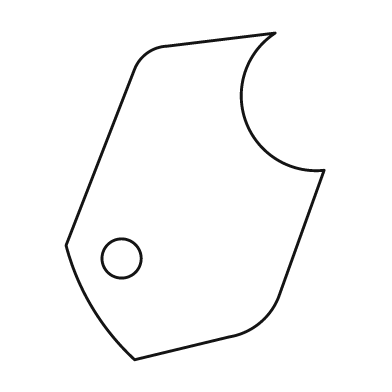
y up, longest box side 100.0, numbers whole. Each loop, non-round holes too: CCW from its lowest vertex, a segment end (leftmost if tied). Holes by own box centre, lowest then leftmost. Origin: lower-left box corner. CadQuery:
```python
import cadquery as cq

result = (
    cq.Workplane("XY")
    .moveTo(21.0, 0.0)
    .lineTo(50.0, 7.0)
    .threePointArc((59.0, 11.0), (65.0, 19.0))
    .lineTo(79.0, 58.0)
    .threePointArc((55.0, 73.0), (64.0, 100.0))
    .lineTo(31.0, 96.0)
    .threePointArc((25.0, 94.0), (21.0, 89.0))
    .lineTo(0.0, 35.0)
    .threePointArc((8.0, 16.0), (21.0, 0.0))
    .close()
    .moveTo(17.0, 31.0)
    .circle(6.0)
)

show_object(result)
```